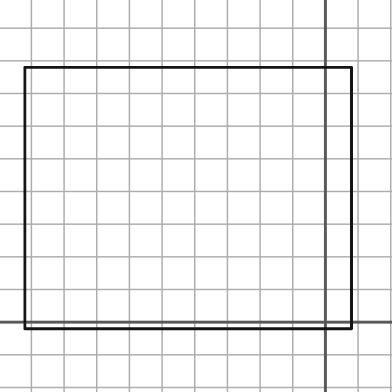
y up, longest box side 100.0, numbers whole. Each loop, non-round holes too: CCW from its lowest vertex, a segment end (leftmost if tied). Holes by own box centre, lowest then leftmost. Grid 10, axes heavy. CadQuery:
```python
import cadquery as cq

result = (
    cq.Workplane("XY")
    .moveTo(-92.0, -2.0)
    .lineTo(8.0, -2.0)
    .lineTo(8.0, 78.0)
    .lineTo(-92.0, 78.0)
    .close()
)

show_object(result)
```